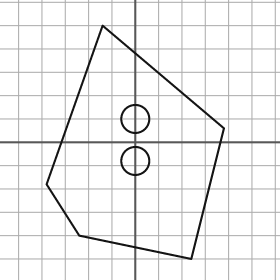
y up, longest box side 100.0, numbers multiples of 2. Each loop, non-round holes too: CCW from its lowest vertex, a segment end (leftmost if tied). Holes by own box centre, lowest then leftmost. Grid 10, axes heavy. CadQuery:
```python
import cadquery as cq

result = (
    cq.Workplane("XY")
    .moveTo(24.0, -50.0)
    .lineTo(38.0, 6.0)
    .lineTo(-14.0, 50.0)
    .lineTo(-38.0, -18.0)
    .lineTo(-24.0, -40.0)
    .close()
    .moveTo(0.0, -8.0)
    .circle(6.0)
    .moveTo(0.0, 10.0)
    .circle(6.0)
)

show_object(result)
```